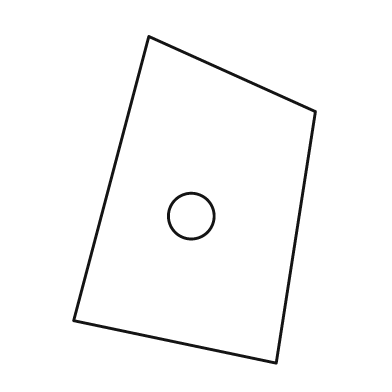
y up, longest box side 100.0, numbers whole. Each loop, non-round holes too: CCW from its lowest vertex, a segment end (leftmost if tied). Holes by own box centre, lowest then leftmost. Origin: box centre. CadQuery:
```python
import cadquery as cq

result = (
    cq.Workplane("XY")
    .moveTo(25.0, -50.0)
    .lineTo(37.0, 27.0)
    .lineTo(-14.0, 50.0)
    .lineTo(-37.0, -37.0)
    .close()
    .moveTo(-1.0, -5.0)
    .circle(7.0)
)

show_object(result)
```